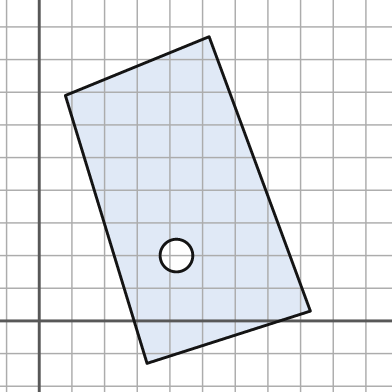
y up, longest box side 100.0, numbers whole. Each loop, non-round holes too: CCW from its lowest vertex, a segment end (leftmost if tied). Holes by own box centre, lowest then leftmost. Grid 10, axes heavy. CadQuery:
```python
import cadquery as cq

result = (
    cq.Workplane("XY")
    .moveTo(33.0, -13.0)
    .lineTo(83.0, 3.0)
    .lineTo(52.0, 87.0)
    .lineTo(8.0, 69.0)
    .close()
    .moveTo(42.0, 20.0)
    .circle(5.0)
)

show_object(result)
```